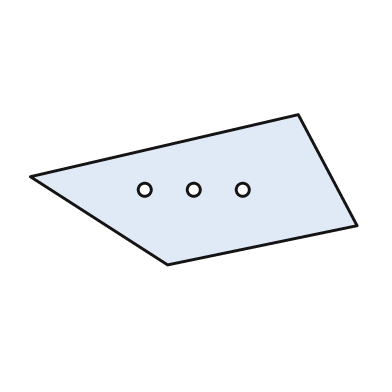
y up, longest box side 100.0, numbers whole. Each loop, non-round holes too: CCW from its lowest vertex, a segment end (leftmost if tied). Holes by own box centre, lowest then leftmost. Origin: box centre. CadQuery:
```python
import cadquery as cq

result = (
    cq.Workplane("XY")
    .moveTo(-8.0, -23.0)
    .lineTo(50.0, -11.0)
    .lineTo(32.0, 23.0)
    .lineTo(-50.0, 4.0)
    .close()
    .moveTo(-15.0, 0.0)
    .circle(2.0)
    .moveTo(0.0, 0.0)
    .circle(2.0)
    .moveTo(15.0, 0.0)
    .circle(2.0)
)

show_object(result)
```